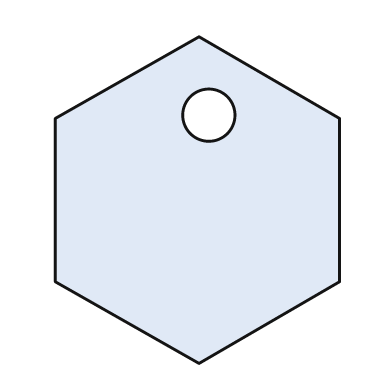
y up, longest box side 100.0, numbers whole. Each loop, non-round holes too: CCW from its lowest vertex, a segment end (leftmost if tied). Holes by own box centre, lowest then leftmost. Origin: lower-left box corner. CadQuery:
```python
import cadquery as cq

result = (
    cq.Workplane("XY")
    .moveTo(44.0, 0.0)
    .lineTo(87.0, 25.0)
    .lineTo(87.0, 75.0)
    .lineTo(44.0, 100.0)
    .lineTo(0.0, 75.0)
    .lineTo(0.0, 25.0)
    .close()
    .moveTo(47.0, 76.0)
    .circle(8.0)
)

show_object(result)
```